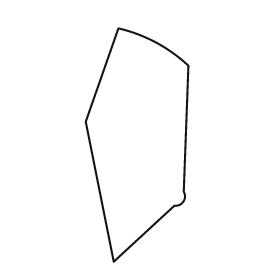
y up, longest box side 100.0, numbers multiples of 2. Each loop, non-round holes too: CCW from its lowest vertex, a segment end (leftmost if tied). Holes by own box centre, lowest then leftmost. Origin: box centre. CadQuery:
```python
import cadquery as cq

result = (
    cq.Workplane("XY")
    .moveTo(-10.0, -50.0)
    .lineTo(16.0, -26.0)
    .threePointArc((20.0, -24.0), (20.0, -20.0))
    .lineTo(22.0, 34.0)
    .threePointArc((8.0, 44.0), (-8.0, 50.0))
    .lineTo(-22.0, 10.0)
    .close()
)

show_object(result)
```